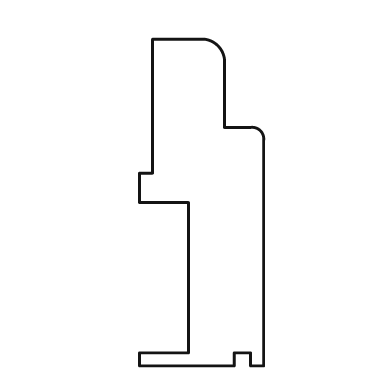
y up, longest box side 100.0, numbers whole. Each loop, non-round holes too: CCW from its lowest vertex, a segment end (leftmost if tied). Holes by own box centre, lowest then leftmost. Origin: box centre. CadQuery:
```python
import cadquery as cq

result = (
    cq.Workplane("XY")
    .moveTo(-19.0, -50.0)
    .lineTo(10.0, -50.0)
    .lineTo(10.0, -46.0)
    .lineTo(15.0, -46.0)
    .lineTo(15.0, -50.0)
    .lineTo(19.0, -50.0)
    .lineTo(19.0, 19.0)
    .threePointArc((18.0, 22.0), (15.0, 23.0))
    .lineTo(7.0, 23.0)
    .lineTo(7.0, 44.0)
    .threePointArc((5.0, 48.0), (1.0, 50.0))
    .lineTo(-15.0, 50.0)
    .lineTo(-15.0, 9.0)
    .lineTo(-19.0, 9.0)
    .lineTo(-19.0, 0.0)
    .lineTo(-4.0, 0.0)
    .lineTo(-4.0, -46.0)
    .lineTo(-19.0, -46.0)
    .close()
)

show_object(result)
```